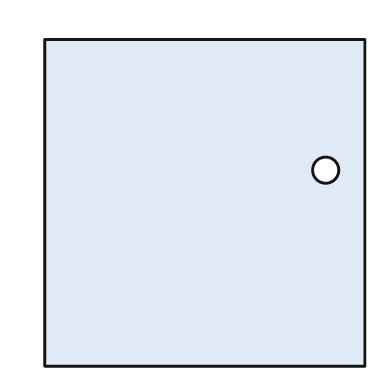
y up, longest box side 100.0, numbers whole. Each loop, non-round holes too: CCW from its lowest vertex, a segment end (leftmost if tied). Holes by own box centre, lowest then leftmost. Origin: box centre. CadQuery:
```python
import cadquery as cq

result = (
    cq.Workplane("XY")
    .moveTo(-49.0, -50.0)
    .lineTo(49.0, -50.0)
    .lineTo(49.0, 50.0)
    .lineTo(-49.0, 50.0)
    .close()
    .moveTo(37.0, 10.0)
    .circle(4.0)
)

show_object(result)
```